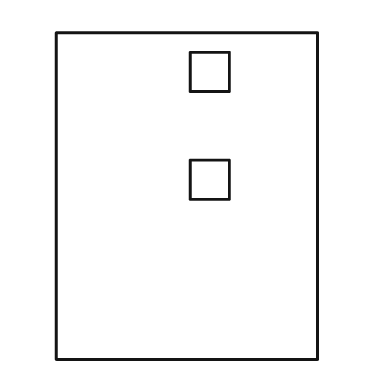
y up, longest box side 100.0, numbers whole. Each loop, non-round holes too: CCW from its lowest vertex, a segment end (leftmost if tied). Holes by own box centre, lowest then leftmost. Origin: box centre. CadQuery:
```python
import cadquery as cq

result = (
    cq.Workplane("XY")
    .moveTo(-40.0, -50.0)
    .lineTo(40.0, -50.0)
    .lineTo(40.0, 50.0)
    .lineTo(-40.0, 50.0)
    .close()
    .moveTo(1.0, -1.0)
    .lineTo(13.0, -1.0)
    .lineTo(13.0, 11.0)
    .lineTo(1.0, 11.0)
    .close()
    .moveTo(1.0, 32.0)
    .lineTo(13.0, 32.0)
    .lineTo(13.0, 44.0)
    .lineTo(1.0, 44.0)
    .close()
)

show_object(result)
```